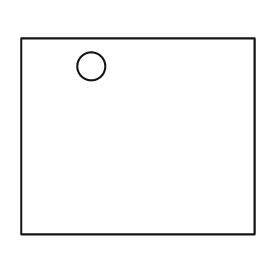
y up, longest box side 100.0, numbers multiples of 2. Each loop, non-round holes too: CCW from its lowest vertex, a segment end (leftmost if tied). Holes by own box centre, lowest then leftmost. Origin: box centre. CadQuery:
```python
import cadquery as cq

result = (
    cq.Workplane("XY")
    .moveTo(-50.0, -42.0)
    .lineTo(50.0, -42.0)
    .lineTo(50.0, 42.0)
    .lineTo(-50.0, 42.0)
    .close()
    .moveTo(-20.0, 30.0)
    .circle(6.0)
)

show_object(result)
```